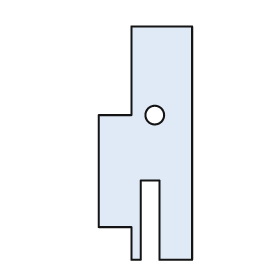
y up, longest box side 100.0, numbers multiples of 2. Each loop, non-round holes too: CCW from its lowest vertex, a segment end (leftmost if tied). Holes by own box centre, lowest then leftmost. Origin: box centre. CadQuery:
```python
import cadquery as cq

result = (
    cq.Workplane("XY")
    .moveTo(-6.0, -50.0)
    .lineTo(-2.0, -50.0)
    .lineTo(-2.0, -16.0)
    .lineTo(6.0, -16.0)
    .lineTo(6.0, -50.0)
    .lineTo(20.0, -50.0)
    .lineTo(20.0, 50.0)
    .lineTo(-6.0, 50.0)
    .lineTo(-6.0, 12.0)
    .lineTo(-20.0, 12.0)
    .lineTo(-20.0, -36.0)
    .lineTo(-6.0, -36.0)
    .close()
    .moveTo(4.0, 12.0)
    .circle(4.0)
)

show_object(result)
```